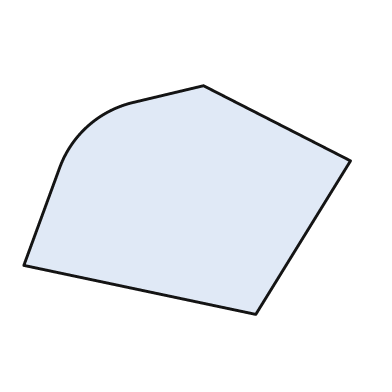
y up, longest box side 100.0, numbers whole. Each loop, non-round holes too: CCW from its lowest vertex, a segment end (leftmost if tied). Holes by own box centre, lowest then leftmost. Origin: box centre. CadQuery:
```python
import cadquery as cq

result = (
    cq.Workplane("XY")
    .moveTo(21.0, -35.0)
    .lineTo(50.0, 12.0)
    .lineTo(5.0, 35.0)
    .lineTo(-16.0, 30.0)
    .threePointArc((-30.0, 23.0), (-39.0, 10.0))
    .lineTo(-50.0, -20.0)
    .close()
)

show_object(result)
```